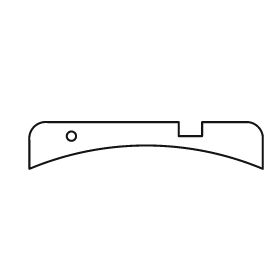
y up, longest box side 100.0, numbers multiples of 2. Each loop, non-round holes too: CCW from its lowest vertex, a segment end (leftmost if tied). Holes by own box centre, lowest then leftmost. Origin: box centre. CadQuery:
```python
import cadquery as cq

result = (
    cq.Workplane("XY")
    .moveTo(-50.0, -10.0)
    .threePointArc((0.0, 0.0), (50.0, -10.0))
    .lineTo(50.0, 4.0)
    .threePointArc((48.0, 8.0), (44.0, 10.0))
    .lineTo(24.0, 10.0)
    .lineTo(24.0, 4.0)
    .lineTo(14.0, 4.0)
    .lineTo(14.0, 10.0)
    .lineTo(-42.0, 10.0)
    .threePointArc((-48.0, 8.0), (-50.0, 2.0))
    .close()
    .moveTo(-32.0, 4.0)
    .circle(2.0)
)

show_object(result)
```